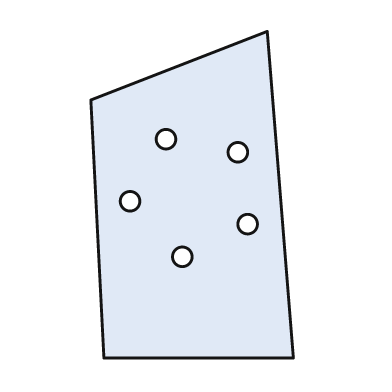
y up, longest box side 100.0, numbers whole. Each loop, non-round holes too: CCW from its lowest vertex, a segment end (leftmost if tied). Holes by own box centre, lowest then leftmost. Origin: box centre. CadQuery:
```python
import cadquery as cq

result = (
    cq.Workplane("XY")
    .moveTo(-27.0, -50.0)
    .lineTo(31.0, -50.0)
    .lineTo(23.0, 50.0)
    .lineTo(-31.0, 29.0)
    .close()
    .moveTo(-3.0, -19.0)
    .circle(3.0)
    .moveTo(17.0, -9.0)
    .circle(3.0)
    .moveTo(-19.0, -2.0)
    .circle(3.0)
    .moveTo(14.0, 13.0)
    .circle(3.0)
    .moveTo(-8.0, 17.0)
    .circle(3.0)
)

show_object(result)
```